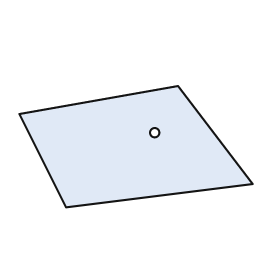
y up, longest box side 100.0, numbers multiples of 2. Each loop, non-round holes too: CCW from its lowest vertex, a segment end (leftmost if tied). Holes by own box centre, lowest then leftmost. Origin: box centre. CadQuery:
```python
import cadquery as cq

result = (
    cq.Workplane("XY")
    .moveTo(-30.0, -26.0)
    .lineTo(50.0, -16.0)
    .lineTo(18.0, 26.0)
    .lineTo(-50.0, 14.0)
    .close()
    .moveTo(8.0, 6.0)
    .circle(2.0)
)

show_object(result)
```